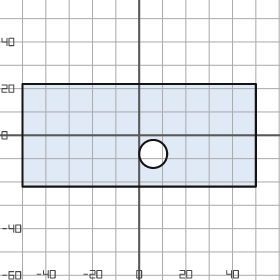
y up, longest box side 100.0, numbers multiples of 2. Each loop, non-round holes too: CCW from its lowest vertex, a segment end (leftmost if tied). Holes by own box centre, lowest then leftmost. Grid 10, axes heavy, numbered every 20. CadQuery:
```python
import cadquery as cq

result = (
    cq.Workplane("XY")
    .moveTo(-50.0, -22.0)
    .lineTo(50.0, -22.0)
    .lineTo(50.0, 22.0)
    .lineTo(-50.0, 22.0)
    .close()
    .moveTo(6.0, -8.0)
    .circle(6.0)
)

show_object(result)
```